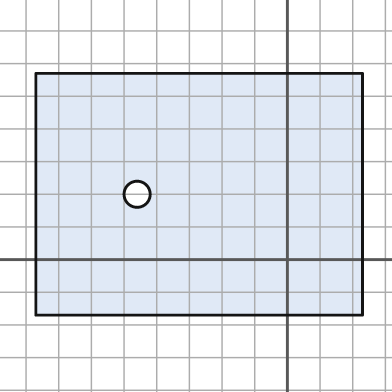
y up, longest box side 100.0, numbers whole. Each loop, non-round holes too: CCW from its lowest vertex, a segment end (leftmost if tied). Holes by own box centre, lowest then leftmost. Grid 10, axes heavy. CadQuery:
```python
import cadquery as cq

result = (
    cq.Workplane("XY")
    .moveTo(-77.0, -17.0)
    .lineTo(23.0, -17.0)
    .lineTo(23.0, 57.0)
    .lineTo(-77.0, 57.0)
    .close()
    .moveTo(-46.0, 20.0)
    .circle(4.0)
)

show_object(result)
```